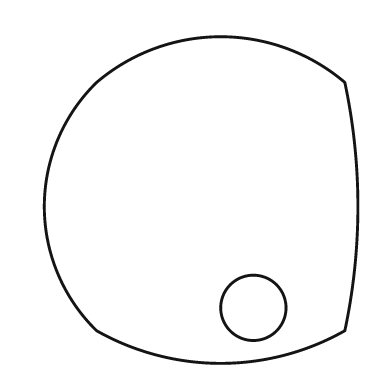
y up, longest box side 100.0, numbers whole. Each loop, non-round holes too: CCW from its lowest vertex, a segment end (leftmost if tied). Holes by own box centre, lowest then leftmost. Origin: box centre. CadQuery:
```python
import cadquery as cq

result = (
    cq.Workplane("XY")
    .moveTo(-32.0, -40.0)
    .threePointArc((6.0, -50.0), (44.0, -40.0))
    .threePointArc((48.0, -2.0), (44.0, 36.0))
    .threePointArc((6.0, 50.0), (-32.0, 36.0))
    .threePointArc((-48.0, -2.0), (-32.0, -40.0))
    .close()
    .moveTo(16.0, -33.0)
    .circle(10.0)
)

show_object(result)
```